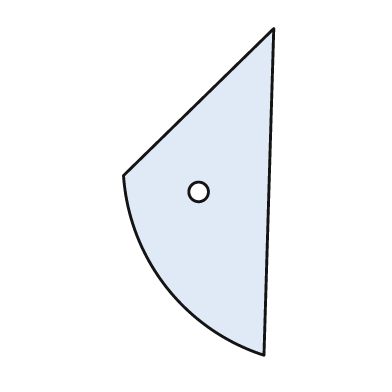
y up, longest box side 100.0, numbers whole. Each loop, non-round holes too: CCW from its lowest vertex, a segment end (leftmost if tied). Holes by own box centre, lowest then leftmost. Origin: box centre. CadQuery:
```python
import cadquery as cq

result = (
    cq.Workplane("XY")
    .moveTo(20.0, -50.0)
    .lineTo(23.0, 50.0)
    .lineTo(-23.0, 5.0)
    .threePointArc((-10.0, -29.0), (20.0, -50.0))
    .close()
    .moveTo(0.0, 0.0)
    .circle(3.0)
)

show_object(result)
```